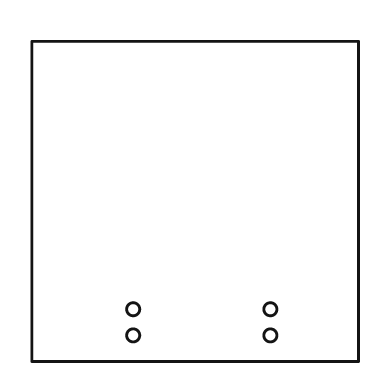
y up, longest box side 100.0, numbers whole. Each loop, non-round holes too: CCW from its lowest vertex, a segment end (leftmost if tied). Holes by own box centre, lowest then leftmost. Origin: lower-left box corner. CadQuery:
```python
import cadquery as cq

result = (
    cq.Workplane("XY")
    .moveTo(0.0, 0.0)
    .lineTo(100.0, 0.0)
    .lineTo(100.0, 98.0)
    .lineTo(0.0, 98.0)
    .close()
    .moveTo(31.0, 8.0)
    .circle(2.0)
    .moveTo(73.0, 8.0)
    .circle(2.0)
    .moveTo(31.0, 16.0)
    .circle(2.0)
    .moveTo(73.0, 16.0)
    .circle(2.0)
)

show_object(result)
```